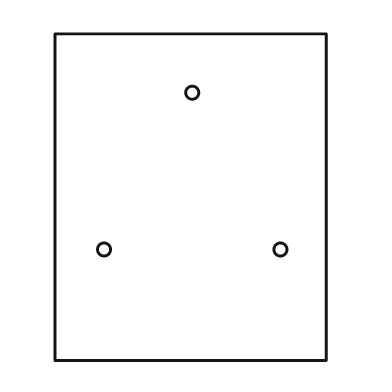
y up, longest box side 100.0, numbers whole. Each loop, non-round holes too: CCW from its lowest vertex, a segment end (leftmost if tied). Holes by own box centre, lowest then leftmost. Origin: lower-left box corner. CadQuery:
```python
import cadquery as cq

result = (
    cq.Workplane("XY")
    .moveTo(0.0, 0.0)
    .lineTo(83.0, 0.0)
    .lineTo(83.0, 100.0)
    .lineTo(0.0, 100.0)
    .close()
    .moveTo(15.0, 34.0)
    .circle(2.0)
    .moveTo(69.0, 34.0)
    .circle(2.0)
    .moveTo(42.0, 82.0)
    .circle(2.0)
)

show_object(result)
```